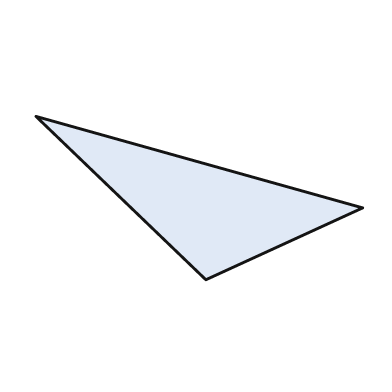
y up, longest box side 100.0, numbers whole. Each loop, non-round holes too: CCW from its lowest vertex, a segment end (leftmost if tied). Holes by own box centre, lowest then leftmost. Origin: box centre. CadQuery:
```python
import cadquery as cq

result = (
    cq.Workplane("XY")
    .moveTo(2.0, -25.0)
    .lineTo(50.0, -3.0)
    .lineTo(-50.0, 25.0)
    .close()
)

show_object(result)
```